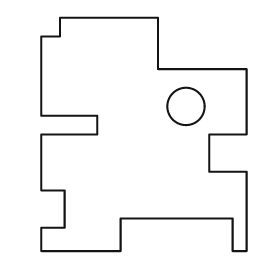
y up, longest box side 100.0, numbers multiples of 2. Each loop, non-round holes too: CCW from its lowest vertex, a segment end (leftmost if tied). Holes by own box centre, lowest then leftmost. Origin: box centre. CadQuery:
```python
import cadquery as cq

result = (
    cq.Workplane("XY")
    .moveTo(-44.0, -50.0)
    .lineTo(-10.0, -50.0)
    .lineTo(-10.0, -36.0)
    .lineTo(38.0, -36.0)
    .lineTo(38.0, -50.0)
    .lineTo(44.0, -50.0)
    .lineTo(44.0, -16.0)
    .lineTo(28.0, -16.0)
    .lineTo(28.0, 0.0)
    .lineTo(44.0, 0.0)
    .lineTo(44.0, 28.0)
    .lineTo(6.0, 28.0)
    .lineTo(6.0, 50.0)
    .lineTo(-36.0, 50.0)
    .lineTo(-36.0, 42.0)
    .lineTo(-44.0, 42.0)
    .lineTo(-44.0, 8.0)
    .lineTo(-20.0, 8.0)
    .lineTo(-20.0, 0.0)
    .lineTo(-44.0, 0.0)
    .lineTo(-44.0, -24.0)
    .lineTo(-34.0, -24.0)
    .lineTo(-34.0, -40.0)
    .lineTo(-44.0, -40.0)
    .close()
    .moveTo(18.0, 12.0)
    .circle(8.0)
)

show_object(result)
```